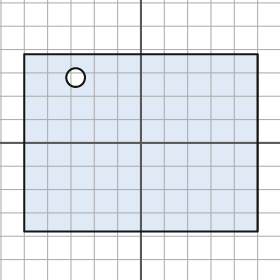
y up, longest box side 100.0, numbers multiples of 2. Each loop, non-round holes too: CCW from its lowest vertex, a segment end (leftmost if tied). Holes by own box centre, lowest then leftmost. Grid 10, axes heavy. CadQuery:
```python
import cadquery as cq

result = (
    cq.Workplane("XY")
    .moveTo(-50.0, -38.0)
    .lineTo(50.0, -38.0)
    .lineTo(50.0, 38.0)
    .lineTo(-50.0, 38.0)
    .close()
    .moveTo(-28.0, 28.0)
    .circle(4.0)
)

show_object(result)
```